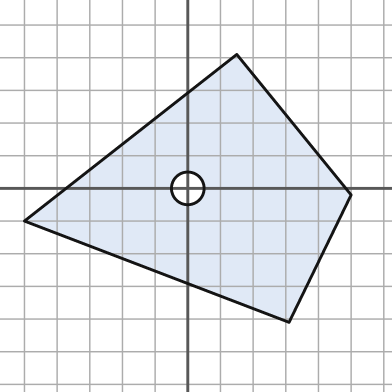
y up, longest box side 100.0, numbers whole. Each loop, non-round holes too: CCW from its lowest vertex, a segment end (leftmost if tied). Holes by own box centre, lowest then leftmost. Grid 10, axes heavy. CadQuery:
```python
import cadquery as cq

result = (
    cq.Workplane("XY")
    .moveTo(31.0, -41.0)
    .lineTo(50.0, -2.0)
    .lineTo(15.0, 41.0)
    .lineTo(-50.0, -10.0)
    .close()
    .moveTo(0.0, 0.0)
    .circle(5.0)
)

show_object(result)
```